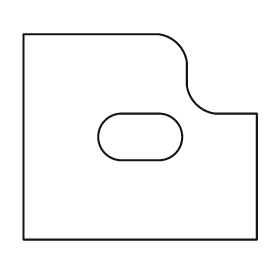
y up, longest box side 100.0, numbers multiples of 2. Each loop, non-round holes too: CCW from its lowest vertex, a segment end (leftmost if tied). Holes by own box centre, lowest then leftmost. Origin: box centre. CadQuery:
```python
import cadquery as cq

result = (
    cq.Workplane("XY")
    .moveTo(-50.0, -44.0)
    .lineTo(50.0, -44.0)
    .lineTo(50.0, 10.0)
    .lineTo(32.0, 10.0)
    .threePointArc((24.0, 14.0), (20.0, 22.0))
    .lineTo(20.0, 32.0)
    .threePointArc((16.0, 40.0), (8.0, 44.0))
    .lineTo(-50.0, 44.0)
    .close()
    .moveTo(-8.0, -10.0)
    .lineTo(8.0, -10.0)
    .threePointArc((18.0, 0.0), (8.0, 10.0))
    .lineTo(-8.0, 10.0)
    .threePointArc((-18.0, 0.0), (-8.0, -10.0))
    .close()
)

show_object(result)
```